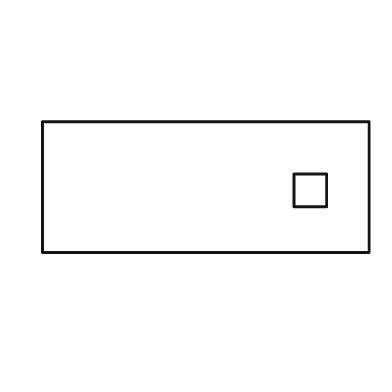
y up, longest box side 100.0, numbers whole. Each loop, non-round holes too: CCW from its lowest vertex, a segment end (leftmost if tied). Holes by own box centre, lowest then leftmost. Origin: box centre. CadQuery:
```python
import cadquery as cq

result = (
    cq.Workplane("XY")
    .moveTo(-50.0, -20.0)
    .lineTo(50.0, -20.0)
    .lineTo(50.0, 20.0)
    .lineTo(-50.0, 20.0)
    .close()
    .moveTo(27.0, -6.0)
    .lineTo(37.0, -6.0)
    .lineTo(37.0, 4.0)
    .lineTo(27.0, 4.0)
    .close()
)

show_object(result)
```